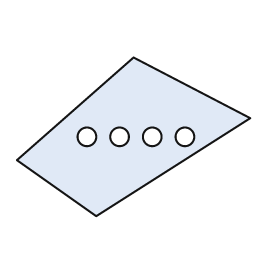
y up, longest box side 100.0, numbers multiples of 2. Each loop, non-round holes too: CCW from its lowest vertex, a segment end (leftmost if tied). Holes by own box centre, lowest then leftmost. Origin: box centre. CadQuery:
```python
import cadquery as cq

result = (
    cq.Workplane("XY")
    .moveTo(-16.0, -34.0)
    .lineTo(50.0, 8.0)
    .lineTo(0.0, 34.0)
    .lineTo(-50.0, -10.0)
    .close()
    .moveTo(-20.0, 0.0)
    .circle(4.0)
    .moveTo(-6.0, 0.0)
    .circle(4.0)
    .moveTo(8.0, 0.0)
    .circle(4.0)
    .moveTo(22.0, 0.0)
    .circle(4.0)
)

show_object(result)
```